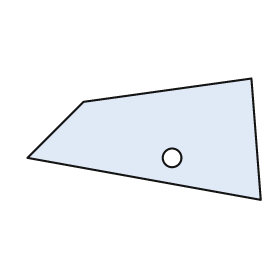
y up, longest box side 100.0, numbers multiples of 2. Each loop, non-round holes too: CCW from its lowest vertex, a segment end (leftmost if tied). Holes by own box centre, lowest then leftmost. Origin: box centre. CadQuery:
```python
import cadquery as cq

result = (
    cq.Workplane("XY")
    .moveTo(50.0, -26.0)
    .lineTo(46.0, 26.0)
    .lineTo(-26.0, 16.0)
    .lineTo(-50.0, -8.0)
    .close()
    .moveTo(12.0, -8.0)
    .circle(4.0)
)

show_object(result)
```